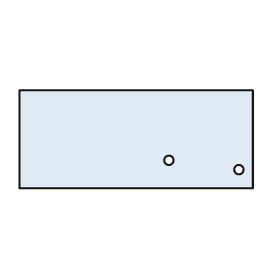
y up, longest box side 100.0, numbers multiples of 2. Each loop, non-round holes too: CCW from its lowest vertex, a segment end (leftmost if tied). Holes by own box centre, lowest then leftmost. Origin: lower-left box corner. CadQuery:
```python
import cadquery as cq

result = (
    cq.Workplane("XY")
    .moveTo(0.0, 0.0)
    .lineTo(100.0, 0.0)
    .lineTo(100.0, 42.0)
    .lineTo(0.0, 42.0)
    .close()
    .moveTo(94.0, 8.0)
    .circle(2.0)
    .moveTo(64.0, 12.0)
    .circle(2.0)
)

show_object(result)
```